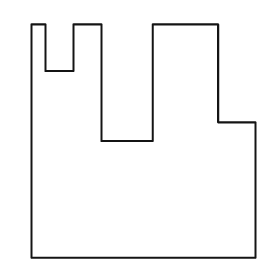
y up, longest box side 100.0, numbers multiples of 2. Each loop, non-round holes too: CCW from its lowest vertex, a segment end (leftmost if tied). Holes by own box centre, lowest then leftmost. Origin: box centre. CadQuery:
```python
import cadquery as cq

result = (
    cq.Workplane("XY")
    .moveTo(-48.0, -50.0)
    .lineTo(48.0, -50.0)
    .lineTo(48.0, 8.0)
    .lineTo(32.0, 8.0)
    .lineTo(32.0, 50.0)
    .lineTo(4.0, 50.0)
    .lineTo(4.0, 0.0)
    .lineTo(-18.0, 0.0)
    .lineTo(-18.0, 50.0)
    .lineTo(-30.0, 50.0)
    .lineTo(-30.0, 30.0)
    .lineTo(-42.0, 30.0)
    .lineTo(-42.0, 50.0)
    .lineTo(-48.0, 50.0)
    .close()
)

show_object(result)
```